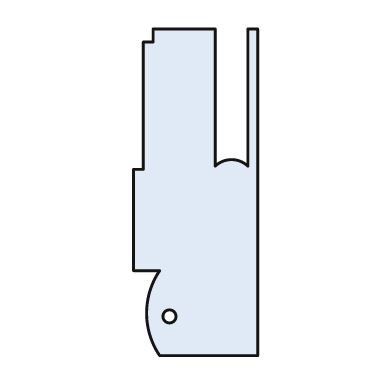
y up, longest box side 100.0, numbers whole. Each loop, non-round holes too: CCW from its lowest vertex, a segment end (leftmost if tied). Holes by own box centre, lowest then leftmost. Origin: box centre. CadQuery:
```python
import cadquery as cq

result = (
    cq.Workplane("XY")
    .moveTo(-11.0, -50.0)
    .lineTo(19.0, -50.0)
    .lineTo(19.0, 50.0)
    .lineTo(16.0, 50.0)
    .lineTo(16.0, 8.0)
    .threePointArc((11.0, 10.0), (6.0, 8.0))
    .lineTo(6.0, 50.0)
    .lineTo(-13.0, 50.0)
    .lineTo(-13.0, 46.0)
    .lineTo(-16.0, 46.0)
    .lineTo(-16.0, 7.0)
    .lineTo(-19.0, 7.0)
    .lineTo(-19.0, -24.0)
    .lineTo(-11.0, -24.0)
    .threePointArc((-15.0, -37.0), (-11.0, -50.0))
    .close()
    .moveTo(-8.0, -38.0)
    .circle(2.0)
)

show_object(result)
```